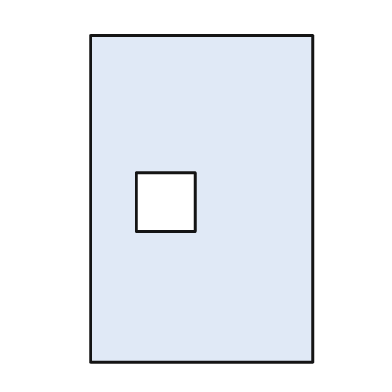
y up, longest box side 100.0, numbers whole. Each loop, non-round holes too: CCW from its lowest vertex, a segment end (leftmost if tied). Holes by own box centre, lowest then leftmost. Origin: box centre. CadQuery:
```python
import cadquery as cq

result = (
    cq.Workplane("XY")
    .moveTo(-34.0, -50.0)
    .lineTo(34.0, -50.0)
    .lineTo(34.0, 50.0)
    .lineTo(-34.0, 50.0)
    .close()
    .moveTo(-20.0, -10.0)
    .lineTo(-2.0, -10.0)
    .lineTo(-2.0, 8.0)
    .lineTo(-20.0, 8.0)
    .close()
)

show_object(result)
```